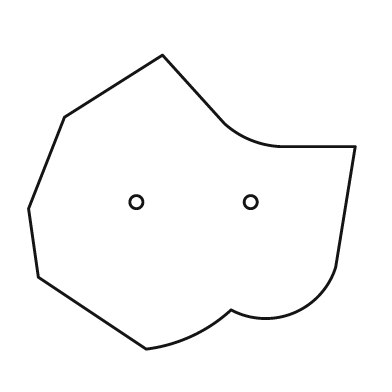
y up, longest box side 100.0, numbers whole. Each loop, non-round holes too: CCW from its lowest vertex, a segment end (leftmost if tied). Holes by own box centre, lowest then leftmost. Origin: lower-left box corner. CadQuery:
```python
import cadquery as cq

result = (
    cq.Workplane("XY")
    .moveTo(36.0, 0.0)
    .threePointArc((50.0, 4.0), (62.0, 12.0))
    .threePointArc((81.0, 11.0), (94.0, 25.0))
    .lineTo(100.0, 62.0)
    .lineTo(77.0, 62.0)
    .threePointArc((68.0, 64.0), (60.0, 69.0))
    .lineTo(41.0, 90.0)
    .lineTo(11.0, 71.0)
    .lineTo(0.0, 43.0)
    .lineTo(3.0, 22.0)
    .close()
    .moveTo(33.0, 45.0)
    .circle(2.0)
    .moveTo(68.0, 45.0)
    .circle(2.0)
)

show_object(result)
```